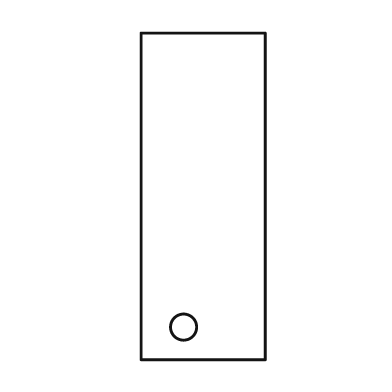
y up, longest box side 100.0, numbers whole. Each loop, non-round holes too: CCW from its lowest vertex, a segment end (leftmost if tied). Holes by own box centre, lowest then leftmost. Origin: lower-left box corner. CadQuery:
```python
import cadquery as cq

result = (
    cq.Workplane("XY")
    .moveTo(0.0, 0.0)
    .lineTo(38.0, 0.0)
    .lineTo(38.0, 100.0)
    .lineTo(0.0, 100.0)
    .close()
    .moveTo(13.0, 10.0)
    .circle(4.0)
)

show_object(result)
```